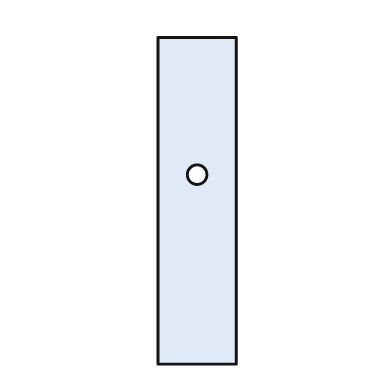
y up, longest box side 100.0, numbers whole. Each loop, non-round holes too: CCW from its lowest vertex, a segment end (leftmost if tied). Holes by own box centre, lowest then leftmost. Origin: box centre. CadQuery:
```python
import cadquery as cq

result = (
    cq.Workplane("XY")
    .moveTo(-12.0, -50.0)
    .lineTo(12.0, -50.0)
    .lineTo(12.0, 50.0)
    .lineTo(-12.0, 50.0)
    .close()
    .moveTo(0.0, 8.0)
    .circle(3.0)
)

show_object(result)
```